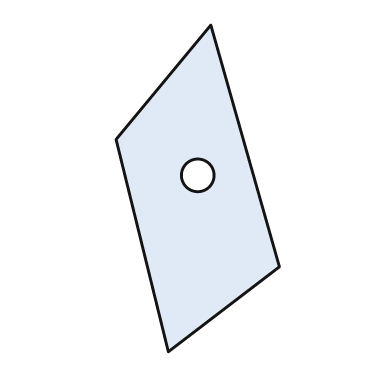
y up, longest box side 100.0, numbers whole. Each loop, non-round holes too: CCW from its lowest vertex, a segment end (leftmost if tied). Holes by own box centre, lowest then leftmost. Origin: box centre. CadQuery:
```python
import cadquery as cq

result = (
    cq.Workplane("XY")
    .moveTo(-9.0, -50.0)
    .lineTo(25.0, -24.0)
    .lineTo(4.0, 50.0)
    .lineTo(-25.0, 15.0)
    .close()
    .moveTo(0.0, 4.0)
    .circle(5.0)
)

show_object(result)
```